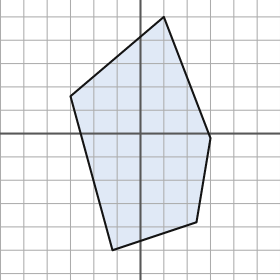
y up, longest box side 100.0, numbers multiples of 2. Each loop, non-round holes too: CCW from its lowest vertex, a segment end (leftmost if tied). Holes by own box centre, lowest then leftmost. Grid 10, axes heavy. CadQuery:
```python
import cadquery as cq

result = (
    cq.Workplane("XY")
    .moveTo(-12.0, -50.0)
    .lineTo(24.0, -38.0)
    .lineTo(30.0, -2.0)
    .lineTo(10.0, 50.0)
    .lineTo(-30.0, 16.0)
    .close()
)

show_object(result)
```